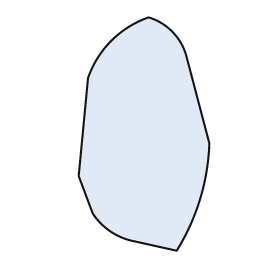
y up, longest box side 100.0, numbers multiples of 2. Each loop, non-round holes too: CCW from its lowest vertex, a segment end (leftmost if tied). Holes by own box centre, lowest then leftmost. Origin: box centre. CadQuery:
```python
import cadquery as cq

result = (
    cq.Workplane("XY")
    .moveTo(14.0, -50.0)
    .threePointArc((24.0, -28.0), (28.0, -4.0))
    .lineTo(18.0, 34.0)
    .threePointArc((12.0, 44.0), (2.0, 50.0))
    .threePointArc((-14.0, 40.0), (-24.0, 24.0))
    .lineTo(-28.0, -18.0)
    .lineTo(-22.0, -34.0)
    .threePointArc((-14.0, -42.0), (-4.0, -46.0))
    .close()
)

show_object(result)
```